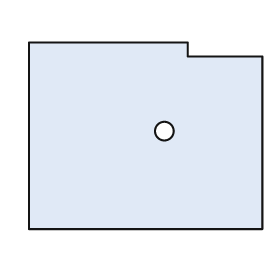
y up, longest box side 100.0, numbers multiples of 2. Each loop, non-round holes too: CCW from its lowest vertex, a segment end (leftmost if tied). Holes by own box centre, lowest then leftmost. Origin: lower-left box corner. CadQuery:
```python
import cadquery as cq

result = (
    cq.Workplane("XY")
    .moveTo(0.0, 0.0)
    .lineTo(100.0, 0.0)
    .lineTo(100.0, 74.0)
    .lineTo(68.0, 74.0)
    .lineTo(68.0, 80.0)
    .lineTo(0.0, 80.0)
    .close()
    .moveTo(58.0, 42.0)
    .circle(4.0)
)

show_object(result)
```